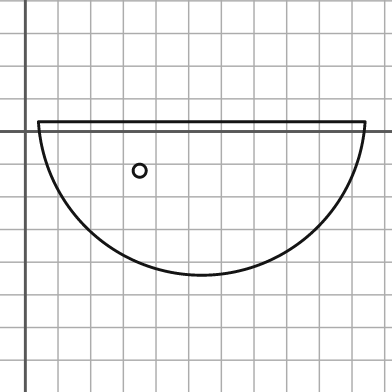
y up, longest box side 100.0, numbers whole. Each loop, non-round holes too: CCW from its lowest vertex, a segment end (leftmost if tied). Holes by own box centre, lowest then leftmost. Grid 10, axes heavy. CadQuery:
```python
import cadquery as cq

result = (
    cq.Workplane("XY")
    .moveTo(4.0, 3.0)
    .threePointArc((54.0, -44.0), (104.0, 3.0))
    .close()
    .moveTo(35.0, -12.0)
    .circle(2.0)
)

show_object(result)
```